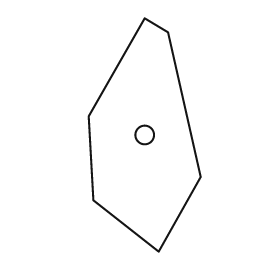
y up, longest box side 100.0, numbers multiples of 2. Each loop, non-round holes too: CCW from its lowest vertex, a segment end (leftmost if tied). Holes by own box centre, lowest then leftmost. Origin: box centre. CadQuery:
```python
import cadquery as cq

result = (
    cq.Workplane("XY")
    .moveTo(6.0, -50.0)
    .lineTo(24.0, -18.0)
    .lineTo(10.0, 44.0)
    .lineTo(0.0, 50.0)
    .lineTo(-24.0, 8.0)
    .lineTo(-22.0, -28.0)
    .close()
    .moveTo(0.0, 0.0)
    .circle(4.0)
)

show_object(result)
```